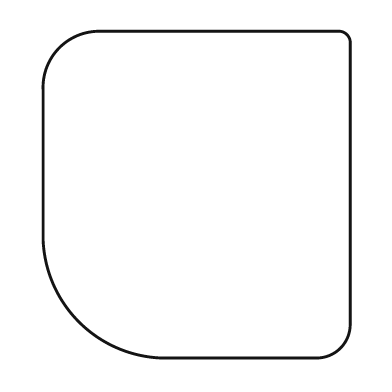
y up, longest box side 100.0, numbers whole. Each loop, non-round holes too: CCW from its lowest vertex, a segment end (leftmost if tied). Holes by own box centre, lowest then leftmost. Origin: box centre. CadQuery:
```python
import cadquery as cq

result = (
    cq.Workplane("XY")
    .moveTo(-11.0, -50.0)
    .lineTo(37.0, -50.0)
    .threePointArc((44.0, -47.0), (47.0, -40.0))
    .lineTo(47.0, 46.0)
    .threePointArc((46.0, 49.0), (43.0, 50.0))
    .lineTo(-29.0, 50.0)
    .threePointArc((-42.0, 45.0), (-47.0, 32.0))
    .lineTo(-47.0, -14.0)
    .threePointArc((-36.0, -39.0), (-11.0, -50.0))
    .close()
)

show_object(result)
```